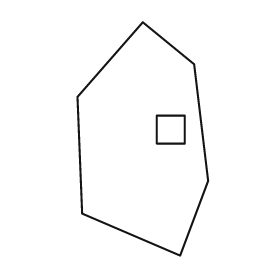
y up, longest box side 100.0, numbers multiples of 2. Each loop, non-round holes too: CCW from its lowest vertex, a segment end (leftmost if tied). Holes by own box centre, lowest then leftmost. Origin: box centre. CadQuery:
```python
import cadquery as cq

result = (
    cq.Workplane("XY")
    .moveTo(16.0, -50.0)
    .lineTo(28.0, -18.0)
    .lineTo(22.0, 32.0)
    .lineTo(0.0, 50.0)
    .lineTo(-28.0, 18.0)
    .lineTo(-26.0, -32.0)
    .close()
    .moveTo(6.0, -2.0)
    .lineTo(18.0, -2.0)
    .lineTo(18.0, 10.0)
    .lineTo(6.0, 10.0)
    .close()
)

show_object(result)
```